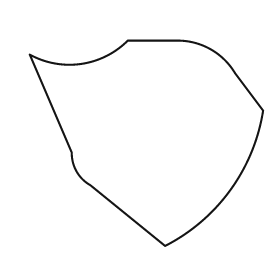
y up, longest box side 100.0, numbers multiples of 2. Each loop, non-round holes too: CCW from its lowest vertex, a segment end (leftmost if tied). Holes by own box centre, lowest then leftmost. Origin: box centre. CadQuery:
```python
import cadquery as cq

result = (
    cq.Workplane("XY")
    .moveTo(8.0, -44.0)
    .threePointArc((36.0, -20.0), (50.0, 14.0))
    .lineTo(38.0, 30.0)
    .threePointArc((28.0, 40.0), (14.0, 44.0))
    .lineTo(-8.0, 44.0)
    .threePointArc((-28.0, 34.0), (-50.0, 38.0))
    .lineTo(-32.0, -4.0)
    .threePointArc((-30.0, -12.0), (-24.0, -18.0))
    .close()
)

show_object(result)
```